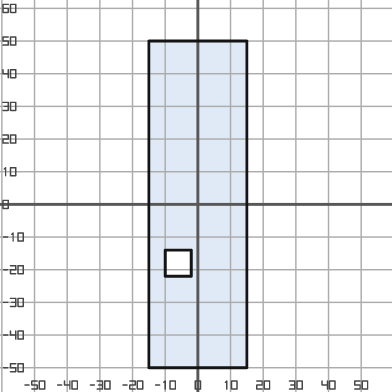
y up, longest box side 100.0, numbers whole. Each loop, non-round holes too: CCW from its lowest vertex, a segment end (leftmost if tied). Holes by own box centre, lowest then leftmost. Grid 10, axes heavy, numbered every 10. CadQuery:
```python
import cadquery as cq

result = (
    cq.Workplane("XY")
    .moveTo(-15.0, -50.0)
    .lineTo(15.0, -50.0)
    .lineTo(15.0, 50.0)
    .lineTo(-15.0, 50.0)
    .close()
    .moveTo(-10.0, -22.0)
    .lineTo(-2.0, -22.0)
    .lineTo(-2.0, -14.0)
    .lineTo(-10.0, -14.0)
    .close()
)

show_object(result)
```